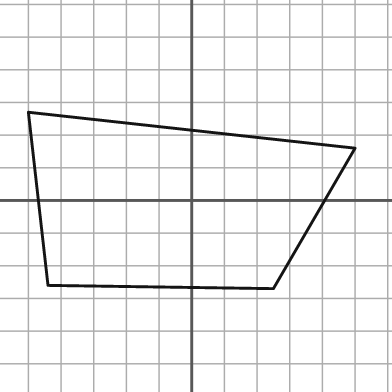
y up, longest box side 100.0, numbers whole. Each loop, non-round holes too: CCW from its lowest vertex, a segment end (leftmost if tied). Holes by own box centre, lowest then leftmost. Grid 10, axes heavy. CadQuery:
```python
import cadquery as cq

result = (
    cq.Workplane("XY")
    .moveTo(25.0, -27.0)
    .lineTo(50.0, 16.0)
    .lineTo(-50.0, 27.0)
    .lineTo(-44.0, -26.0)
    .close()
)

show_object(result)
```